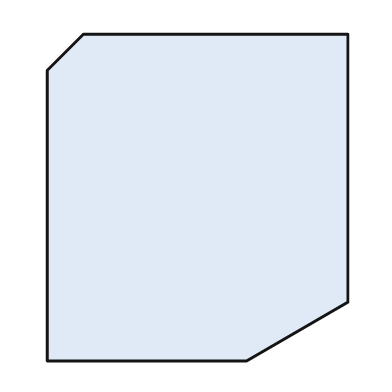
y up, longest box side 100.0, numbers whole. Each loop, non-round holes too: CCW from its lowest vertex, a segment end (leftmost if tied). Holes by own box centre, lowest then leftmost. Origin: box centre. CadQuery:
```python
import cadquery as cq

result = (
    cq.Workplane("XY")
    .moveTo(-46.0, -50.0)
    .lineTo(15.0, -50.0)
    .lineTo(46.0, -32.0)
    .lineTo(46.0, 50.0)
    .lineTo(-35.0, 50.0)
    .lineTo(-46.0, 39.0)
    .close()
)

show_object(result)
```